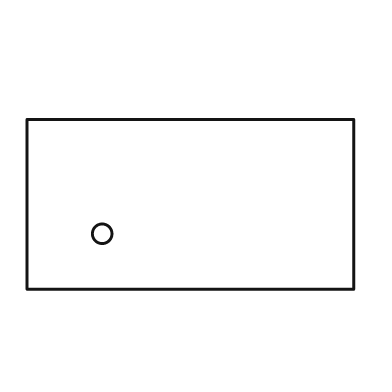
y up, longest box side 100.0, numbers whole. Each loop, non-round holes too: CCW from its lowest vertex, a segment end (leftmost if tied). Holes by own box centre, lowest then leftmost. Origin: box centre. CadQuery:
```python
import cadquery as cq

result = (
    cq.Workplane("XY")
    .moveTo(-50.0, -26.0)
    .lineTo(50.0, -26.0)
    .lineTo(50.0, 26.0)
    .lineTo(-50.0, 26.0)
    .close()
    .moveTo(-27.0, -9.0)
    .circle(3.0)
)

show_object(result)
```